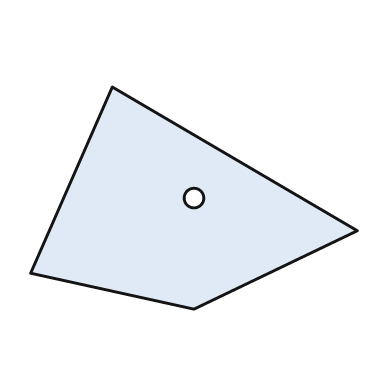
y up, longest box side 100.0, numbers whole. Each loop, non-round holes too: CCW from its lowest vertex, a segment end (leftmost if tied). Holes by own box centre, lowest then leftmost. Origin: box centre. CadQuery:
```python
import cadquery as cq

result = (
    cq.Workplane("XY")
    .moveTo(0.0, -34.0)
    .lineTo(50.0, -10.0)
    .lineTo(-25.0, 34.0)
    .lineTo(-50.0, -23.0)
    .close()
    .moveTo(0.0, 0.0)
    .circle(3.0)
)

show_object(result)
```